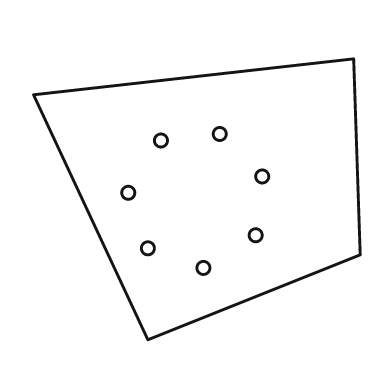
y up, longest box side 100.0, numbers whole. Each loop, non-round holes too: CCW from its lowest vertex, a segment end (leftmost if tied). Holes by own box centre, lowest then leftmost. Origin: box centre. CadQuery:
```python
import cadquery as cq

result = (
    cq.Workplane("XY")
    .moveTo(-15.0, -43.0)
    .lineTo(50.0, -17.0)
    .lineTo(48.0, 43.0)
    .lineTo(-50.0, 32.0)
    .close()
    .moveTo(2.0, -21.0)
    .circle(2.0)
    .moveTo(-15.0, -15.0)
    .circle(2.0)
    .moveTo(18.0, -11.0)
    .circle(2.0)
    .moveTo(-21.0, 2.0)
    .circle(2.0)
    .moveTo(20.0, 7.0)
    .circle(2.0)
    .moveTo(-11.0, 18.0)
    .circle(2.0)
    .moveTo(7.0, 20.0)
    .circle(2.0)
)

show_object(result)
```